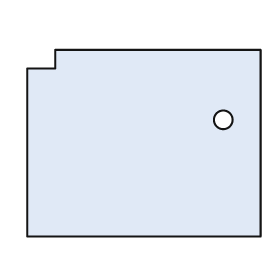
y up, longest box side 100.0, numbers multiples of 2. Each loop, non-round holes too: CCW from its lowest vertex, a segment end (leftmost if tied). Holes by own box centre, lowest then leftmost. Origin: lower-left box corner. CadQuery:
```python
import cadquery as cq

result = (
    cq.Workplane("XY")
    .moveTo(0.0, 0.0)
    .lineTo(100.0, 0.0)
    .lineTo(100.0, 80.0)
    .lineTo(12.0, 80.0)
    .lineTo(12.0, 72.0)
    .lineTo(0.0, 72.0)
    .close()
    .moveTo(84.0, 50.0)
    .circle(4.0)
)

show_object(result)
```